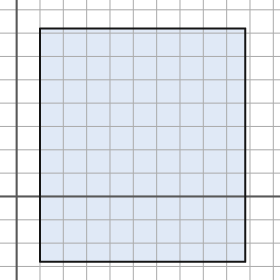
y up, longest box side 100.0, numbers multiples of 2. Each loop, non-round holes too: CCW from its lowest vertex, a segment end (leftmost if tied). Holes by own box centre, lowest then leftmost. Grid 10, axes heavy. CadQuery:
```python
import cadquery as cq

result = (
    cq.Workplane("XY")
    .moveTo(10.0, -28.0)
    .lineTo(98.0, -28.0)
    .lineTo(98.0, 72.0)
    .lineTo(10.0, 72.0)
    .close()
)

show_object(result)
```